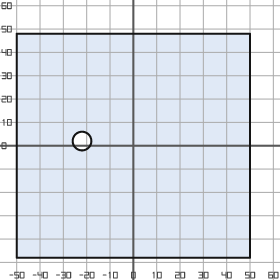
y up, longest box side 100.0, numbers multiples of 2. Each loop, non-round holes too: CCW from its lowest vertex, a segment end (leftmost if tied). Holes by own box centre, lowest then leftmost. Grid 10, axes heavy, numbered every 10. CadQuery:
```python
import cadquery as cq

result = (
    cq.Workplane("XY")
    .moveTo(-50.0, -48.0)
    .lineTo(50.0, -48.0)
    .lineTo(50.0, 48.0)
    .lineTo(-50.0, 48.0)
    .close()
    .moveTo(-22.0, 2.0)
    .circle(4.0)
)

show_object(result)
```